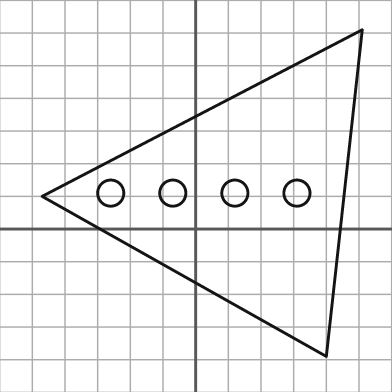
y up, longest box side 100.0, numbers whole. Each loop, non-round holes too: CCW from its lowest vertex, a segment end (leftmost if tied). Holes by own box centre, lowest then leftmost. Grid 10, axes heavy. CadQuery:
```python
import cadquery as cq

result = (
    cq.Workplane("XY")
    .moveTo(40.0, -39.0)
    .lineTo(51.0, 61.0)
    .lineTo(-47.0, 10.0)
    .close()
    .moveTo(-26.0, 11.0)
    .circle(4.0)
    .moveTo(-7.0, 11.0)
    .circle(4.0)
    .moveTo(12.0, 11.0)
    .circle(4.0)
    .moveTo(31.0, 11.0)
    .circle(4.0)
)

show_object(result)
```